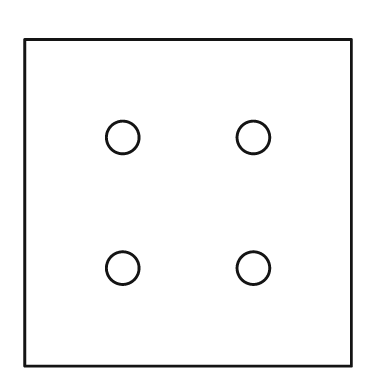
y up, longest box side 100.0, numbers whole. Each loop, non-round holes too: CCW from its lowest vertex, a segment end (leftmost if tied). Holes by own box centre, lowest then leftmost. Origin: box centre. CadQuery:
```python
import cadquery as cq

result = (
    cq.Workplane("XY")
    .moveTo(-50.0, -50.0)
    .lineTo(50.0, -50.0)
    .lineTo(50.0, 50.0)
    .lineTo(-50.0, 50.0)
    .close()
    .moveTo(-20.0, -20.0)
    .circle(5.0)
    .moveTo(20.0, -20.0)
    .circle(5.0)
    .moveTo(-20.0, 20.0)
    .circle(5.0)
    .moveTo(20.0, 20.0)
    .circle(5.0)
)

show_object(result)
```